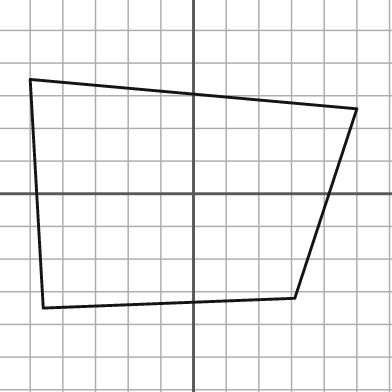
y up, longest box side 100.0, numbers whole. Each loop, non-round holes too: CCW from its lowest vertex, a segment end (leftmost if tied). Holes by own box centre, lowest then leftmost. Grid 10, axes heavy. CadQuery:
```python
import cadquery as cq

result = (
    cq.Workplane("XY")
    .moveTo(-46.0, -35.0)
    .lineTo(31.0, -32.0)
    .lineTo(50.0, 26.0)
    .lineTo(-50.0, 35.0)
    .close()
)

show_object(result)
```